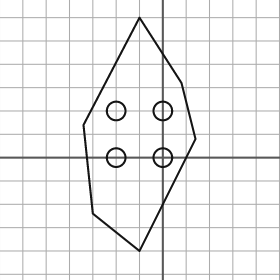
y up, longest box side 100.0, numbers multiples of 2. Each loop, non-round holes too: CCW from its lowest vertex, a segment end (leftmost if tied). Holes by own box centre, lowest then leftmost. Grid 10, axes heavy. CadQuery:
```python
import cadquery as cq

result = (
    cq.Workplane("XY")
    .moveTo(-10.0, -40.0)
    .lineTo(14.0, 8.0)
    .lineTo(8.0, 32.0)
    .lineTo(-10.0, 60.0)
    .lineTo(-34.0, 14.0)
    .lineTo(-30.0, -24.0)
    .close()
    .moveTo(-20.0, 0.0)
    .circle(4.0)
    .moveTo(0.0, 0.0)
    .circle(4.0)
    .moveTo(-20.0, 20.0)
    .circle(4.0)
    .moveTo(0.0, 20.0)
    .circle(4.0)
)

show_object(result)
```